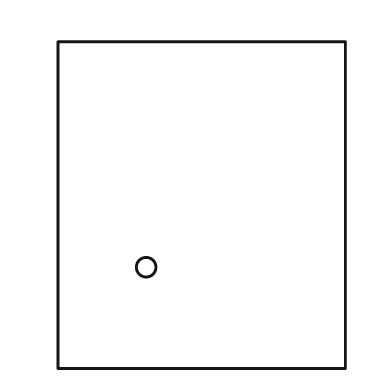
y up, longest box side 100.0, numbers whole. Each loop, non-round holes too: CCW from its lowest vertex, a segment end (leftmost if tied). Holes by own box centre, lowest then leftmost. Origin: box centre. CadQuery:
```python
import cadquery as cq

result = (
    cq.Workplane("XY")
    .moveTo(-44.0, -50.0)
    .lineTo(44.0, -50.0)
    .lineTo(44.0, 50.0)
    .lineTo(-44.0, 50.0)
    .close()
    .moveTo(-17.0, -19.0)
    .circle(3.0)
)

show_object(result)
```